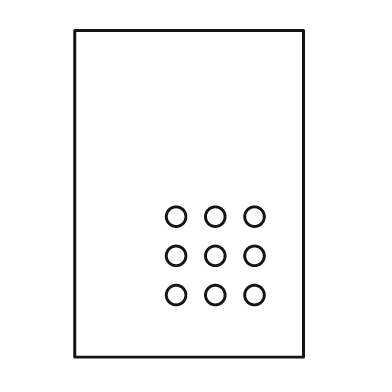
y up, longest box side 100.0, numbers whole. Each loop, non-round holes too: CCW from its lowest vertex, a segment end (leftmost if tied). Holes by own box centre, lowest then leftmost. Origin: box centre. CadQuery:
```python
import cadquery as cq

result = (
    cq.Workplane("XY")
    .moveTo(-35.0, -50.0)
    .lineTo(35.0, -50.0)
    .lineTo(35.0, 50.0)
    .lineTo(-35.0, 50.0)
    .close()
    .moveTo(-4.0, -31.0)
    .circle(3.0)
    .moveTo(8.0, -31.0)
    .circle(3.0)
    .moveTo(20.0, -31.0)
    .circle(3.0)
    .moveTo(-4.0, -19.0)
    .circle(3.0)
    .moveTo(8.0, -19.0)
    .circle(3.0)
    .moveTo(20.0, -19.0)
    .circle(3.0)
    .moveTo(-4.0, -7.0)
    .circle(3.0)
    .moveTo(8.0, -7.0)
    .circle(3.0)
    .moveTo(20.0, -7.0)
    .circle(3.0)
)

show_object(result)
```